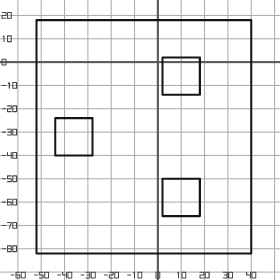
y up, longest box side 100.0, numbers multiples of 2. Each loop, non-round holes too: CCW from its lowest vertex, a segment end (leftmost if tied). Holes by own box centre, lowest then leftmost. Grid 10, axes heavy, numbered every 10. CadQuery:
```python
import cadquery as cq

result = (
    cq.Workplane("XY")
    .moveTo(-52.0, -82.0)
    .lineTo(40.0, -82.0)
    .lineTo(40.0, 18.0)
    .lineTo(-52.0, 18.0)
    .close()
    .moveTo(2.0, -66.0)
    .lineTo(18.0, -66.0)
    .lineTo(18.0, -50.0)
    .lineTo(2.0, -50.0)
    .close()
    .moveTo(-44.0, -40.0)
    .lineTo(-28.0, -40.0)
    .lineTo(-28.0, -24.0)
    .lineTo(-44.0, -24.0)
    .close()
    .moveTo(2.0, -14.0)
    .lineTo(18.0, -14.0)
    .lineTo(18.0, 2.0)
    .lineTo(2.0, 2.0)
    .close()
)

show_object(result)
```